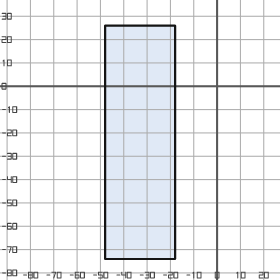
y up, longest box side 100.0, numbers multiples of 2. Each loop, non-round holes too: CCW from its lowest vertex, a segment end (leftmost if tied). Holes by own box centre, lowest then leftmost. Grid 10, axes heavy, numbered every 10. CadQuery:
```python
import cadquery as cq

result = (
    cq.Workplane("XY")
    .moveTo(-48.0, -74.0)
    .lineTo(-18.0, -74.0)
    .lineTo(-18.0, 26.0)
    .lineTo(-48.0, 26.0)
    .close()
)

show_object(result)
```